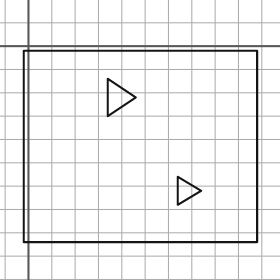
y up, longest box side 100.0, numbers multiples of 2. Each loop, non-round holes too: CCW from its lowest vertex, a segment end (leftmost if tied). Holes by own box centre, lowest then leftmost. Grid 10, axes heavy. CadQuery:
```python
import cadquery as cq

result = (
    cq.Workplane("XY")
    .moveTo(-2.0, -84.0)
    .lineTo(98.0, -84.0)
    .lineTo(98.0, -2.0)
    .lineTo(-2.0, -2.0)
    .close()
    .moveTo(64.0, -68.0)
    .lineTo(74.0, -62.0)
    .lineTo(64.0, -56.0)
    .close()
    .moveTo(34.0, -30.0)
    .lineTo(46.0, -22.0)
    .lineTo(34.0, -14.0)
    .close()
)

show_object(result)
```